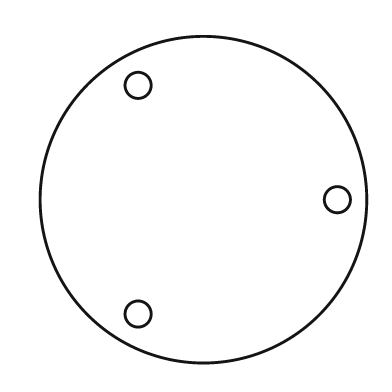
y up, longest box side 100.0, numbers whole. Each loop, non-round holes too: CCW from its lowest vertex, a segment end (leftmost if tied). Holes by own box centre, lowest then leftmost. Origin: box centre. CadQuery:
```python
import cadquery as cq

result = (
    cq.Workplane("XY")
    .moveTo(0.0, 0.0)
    .circle(50.0)
    .moveTo(-20.0, -35.0)
    .circle(4.0)
    .moveTo(41.0, 0.0)
    .circle(4.0)
    .moveTo(-20.0, 35.0)
    .circle(4.0)
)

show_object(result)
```